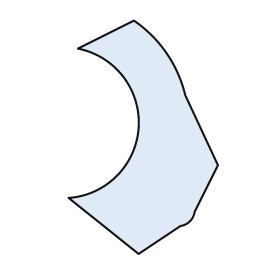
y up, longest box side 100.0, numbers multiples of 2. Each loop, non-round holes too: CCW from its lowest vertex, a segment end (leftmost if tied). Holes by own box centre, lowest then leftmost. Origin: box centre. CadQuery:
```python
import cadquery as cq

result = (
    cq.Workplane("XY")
    .moveTo(-2.0, -50.0)
    .lineTo(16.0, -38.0)
    .threePointArc((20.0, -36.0), (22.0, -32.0))
    .lineTo(32.0, -12.0)
    .lineTo(18.0, 18.0)
    .threePointArc((10.0, 36.0), (-4.0, 50.0))
    .lineTo(-28.0, 38.0)
    .threePointArc((-2.0, 4.0), (-32.0, -26.0))
    .close()
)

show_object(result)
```